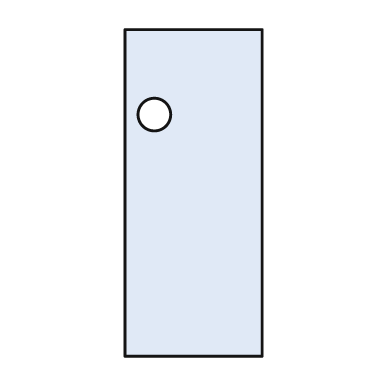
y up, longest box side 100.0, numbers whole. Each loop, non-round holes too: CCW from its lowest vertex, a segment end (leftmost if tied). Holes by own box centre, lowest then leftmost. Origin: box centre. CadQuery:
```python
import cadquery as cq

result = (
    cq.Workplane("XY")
    .moveTo(-21.0, -50.0)
    .lineTo(21.0, -50.0)
    .lineTo(21.0, 50.0)
    .lineTo(-21.0, 50.0)
    .close()
    .moveTo(-12.0, 24.0)
    .circle(5.0)
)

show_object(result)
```